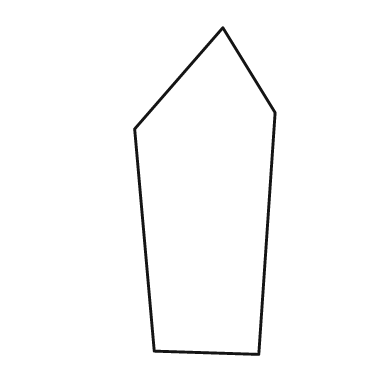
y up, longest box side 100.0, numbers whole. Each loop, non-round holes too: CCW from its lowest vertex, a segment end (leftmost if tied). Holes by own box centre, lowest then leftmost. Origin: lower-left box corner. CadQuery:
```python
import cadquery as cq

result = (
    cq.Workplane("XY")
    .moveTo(38.0, 0.0)
    .lineTo(43.0, 74.0)
    .lineTo(27.0, 100.0)
    .lineTo(0.0, 69.0)
    .lineTo(6.0, 1.0)
    .close()
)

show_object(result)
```